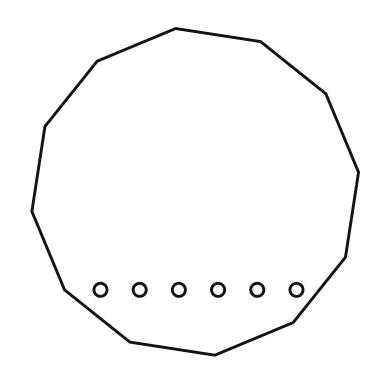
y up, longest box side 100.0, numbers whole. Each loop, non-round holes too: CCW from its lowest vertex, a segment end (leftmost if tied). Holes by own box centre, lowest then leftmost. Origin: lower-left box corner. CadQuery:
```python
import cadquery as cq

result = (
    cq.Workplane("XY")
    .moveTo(56.0, 0.0)
    .lineTo(80.0, 10.0)
    .lineTo(96.0, 30.0)
    .lineTo(100.0, 56.0)
    .lineTo(90.0, 80.0)
    .lineTo(70.0, 96.0)
    .lineTo(44.0, 100.0)
    .lineTo(20.0, 90.0)
    .lineTo(4.0, 70.0)
    .lineTo(0.0, 44.0)
    .lineTo(10.0, 20.0)
    .lineTo(30.0, 4.0)
    .close()
    .moveTo(21.0, 20.0)
    .circle(2.0)
    .moveTo(33.0, 20.0)
    .circle(2.0)
    .moveTo(45.0, 20.0)
    .circle(2.0)
    .moveTo(57.0, 20.0)
    .circle(2.0)
    .moveTo(69.0, 20.0)
    .circle(2.0)
    .moveTo(81.0, 20.0)
    .circle(2.0)
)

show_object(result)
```